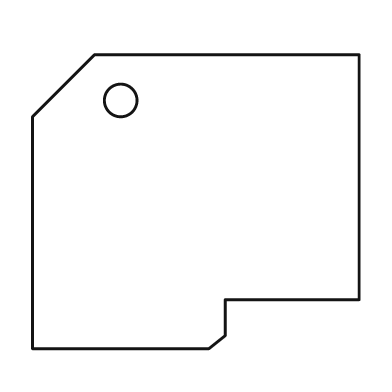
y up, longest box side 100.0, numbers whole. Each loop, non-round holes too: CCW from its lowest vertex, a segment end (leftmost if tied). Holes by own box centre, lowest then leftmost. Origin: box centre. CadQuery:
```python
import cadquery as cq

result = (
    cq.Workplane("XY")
    .moveTo(-50.0, -45.0)
    .lineTo(4.0, -45.0)
    .lineTo(9.0, -41.0)
    .lineTo(9.0, -30.0)
    .lineTo(50.0, -30.0)
    .lineTo(50.0, 45.0)
    .lineTo(-31.0, 45.0)
    .lineTo(-50.0, 26.0)
    .close()
    .moveTo(-23.0, 31.0)
    .circle(5.0)
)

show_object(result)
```